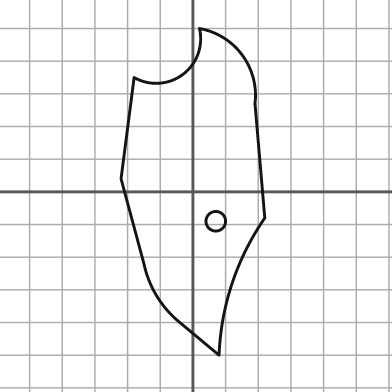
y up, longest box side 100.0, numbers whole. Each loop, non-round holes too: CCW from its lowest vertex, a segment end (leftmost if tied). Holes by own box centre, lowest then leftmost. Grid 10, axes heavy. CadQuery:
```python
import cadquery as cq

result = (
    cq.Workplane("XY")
    .moveTo(8.0, -50.0)
    .threePointArc((12.0, -28.0), (22.0, -8.0))
    .lineTo(19.0, 27.0)
    .threePointArc((15.0, 42.0), (2.0, 50.0))
    .threePointArc((-3.0, 36.0), (-18.0, 35.0))
    .lineTo(-22.0, 4.0)
    .lineTo(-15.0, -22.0)
    .threePointArc((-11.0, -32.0), (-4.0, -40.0))
    .close()
    .moveTo(7.0, -9.0)
    .circle(3.0)
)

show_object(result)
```